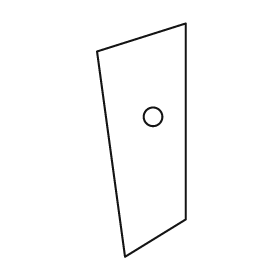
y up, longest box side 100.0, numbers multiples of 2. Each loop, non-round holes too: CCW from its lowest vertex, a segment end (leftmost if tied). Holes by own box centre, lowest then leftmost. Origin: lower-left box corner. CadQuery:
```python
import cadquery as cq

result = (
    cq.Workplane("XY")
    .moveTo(12.0, 0.0)
    .lineTo(38.0, 16.0)
    .lineTo(38.0, 100.0)
    .lineTo(0.0, 88.0)
    .close()
    .moveTo(24.0, 60.0)
    .circle(4.0)
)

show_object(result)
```